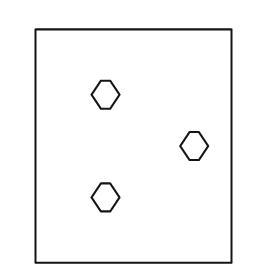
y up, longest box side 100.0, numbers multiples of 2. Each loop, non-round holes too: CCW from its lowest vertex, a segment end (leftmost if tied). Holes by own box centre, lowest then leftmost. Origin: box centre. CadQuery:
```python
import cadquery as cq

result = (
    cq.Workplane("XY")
    .moveTo(-42.0, -50.0)
    .lineTo(42.0, -50.0)
    .lineTo(42.0, 50.0)
    .lineTo(-42.0, 50.0)
    .close()
    .moveTo(-14.0, -28.0)
    .lineTo(-10.0, -28.0)
    .lineTo(-6.0, -22.0)
    .lineTo(-10.0, -16.0)
    .lineTo(-14.0, -16.0)
    .lineTo(-18.0, -22.0)
    .close()
    .moveTo(24.0, -6.0)
    .lineTo(28.0, -6.0)
    .lineTo(32.0, 0.0)
    .lineTo(28.0, 6.0)
    .lineTo(24.0, 6.0)
    .lineTo(20.0, 0.0)
    .close()
    .moveTo(-14.0, 16.0)
    .lineTo(-10.0, 16.0)
    .lineTo(-6.0, 22.0)
    .lineTo(-10.0, 28.0)
    .lineTo(-14.0, 28.0)
    .lineTo(-18.0, 22.0)
    .close()
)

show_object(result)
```